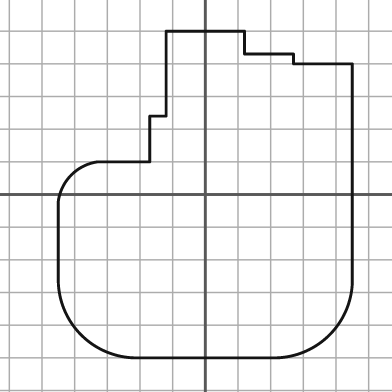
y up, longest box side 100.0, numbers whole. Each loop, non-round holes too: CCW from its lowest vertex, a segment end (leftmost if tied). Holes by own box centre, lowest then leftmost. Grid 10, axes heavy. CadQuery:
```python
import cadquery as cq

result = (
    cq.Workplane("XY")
    .moveTo(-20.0, -50.0)
    .lineTo(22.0, -50.0)
    .threePointArc((38.0, -43.0), (45.0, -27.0))
    .lineTo(45.0, 40.0)
    .lineTo(27.0, 40.0)
    .lineTo(27.0, 43.0)
    .lineTo(12.0, 43.0)
    .lineTo(12.0, 50.0)
    .lineTo(-12.0, 50.0)
    .lineTo(-12.0, 24.0)
    .lineTo(-17.0, 24.0)
    .lineTo(-17.0, 10.0)
    .lineTo(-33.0, 10.0)
    .threePointArc((-41.0, 6.0), (-45.0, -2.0))
    .lineTo(-45.0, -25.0)
    .threePointArc((-38.0, -43.0), (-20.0, -50.0))
    .close()
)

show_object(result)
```